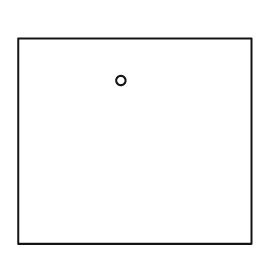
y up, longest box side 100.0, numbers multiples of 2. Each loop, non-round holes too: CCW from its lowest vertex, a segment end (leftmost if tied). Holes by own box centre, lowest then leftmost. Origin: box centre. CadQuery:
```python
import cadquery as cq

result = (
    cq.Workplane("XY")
    .moveTo(-50.0, -44.0)
    .lineTo(50.0, -44.0)
    .lineTo(50.0, 44.0)
    .lineTo(-50.0, 44.0)
    .close()
    .moveTo(-6.0, 26.0)
    .circle(2.0)
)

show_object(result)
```